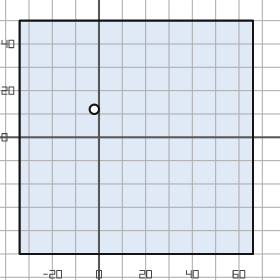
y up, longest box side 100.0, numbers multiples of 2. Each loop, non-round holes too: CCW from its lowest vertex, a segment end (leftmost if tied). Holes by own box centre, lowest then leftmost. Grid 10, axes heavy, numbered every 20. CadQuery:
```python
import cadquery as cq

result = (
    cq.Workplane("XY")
    .moveTo(-34.0, -50.0)
    .lineTo(66.0, -50.0)
    .lineTo(66.0, 50.0)
    .lineTo(-34.0, 50.0)
    .close()
    .moveTo(-2.0, 12.0)
    .circle(2.0)
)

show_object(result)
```